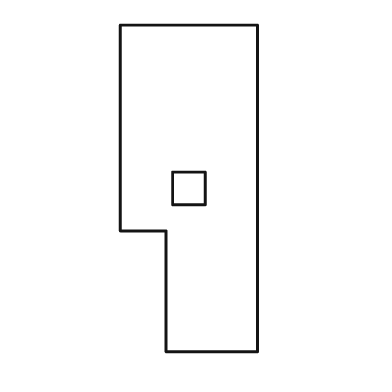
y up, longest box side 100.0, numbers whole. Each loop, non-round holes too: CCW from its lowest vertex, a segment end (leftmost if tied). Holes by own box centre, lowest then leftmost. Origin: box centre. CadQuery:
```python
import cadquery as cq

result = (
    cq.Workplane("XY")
    .moveTo(-7.0, -50.0)
    .lineTo(21.0, -50.0)
    .lineTo(21.0, 50.0)
    .lineTo(-21.0, 50.0)
    .lineTo(-21.0, -13.0)
    .lineTo(-7.0, -13.0)
    .close()
    .moveTo(-5.0, -5.0)
    .lineTo(5.0, -5.0)
    .lineTo(5.0, 5.0)
    .lineTo(-5.0, 5.0)
    .close()
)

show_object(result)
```